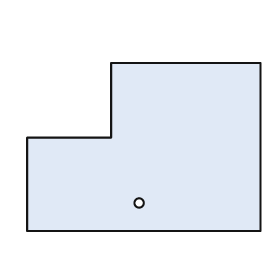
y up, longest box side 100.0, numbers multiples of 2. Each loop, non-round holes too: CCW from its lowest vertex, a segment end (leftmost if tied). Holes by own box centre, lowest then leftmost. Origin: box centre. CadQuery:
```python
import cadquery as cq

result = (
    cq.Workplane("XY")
    .moveTo(-50.0, -36.0)
    .lineTo(50.0, -36.0)
    .lineTo(50.0, 36.0)
    .lineTo(-14.0, 36.0)
    .lineTo(-14.0, 4.0)
    .lineTo(-50.0, 4.0)
    .close()
    .moveTo(-2.0, -24.0)
    .circle(2.0)
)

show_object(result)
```